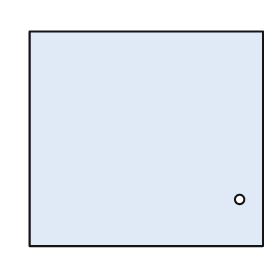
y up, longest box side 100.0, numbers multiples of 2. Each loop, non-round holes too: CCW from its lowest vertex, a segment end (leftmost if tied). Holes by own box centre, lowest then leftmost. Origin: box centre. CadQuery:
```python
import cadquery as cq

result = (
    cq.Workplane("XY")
    .moveTo(-50.0, -46.0)
    .lineTo(50.0, -46.0)
    .lineTo(50.0, 46.0)
    .lineTo(-50.0, 46.0)
    .close()
    .moveTo(40.0, -26.0)
    .circle(2.0)
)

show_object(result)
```